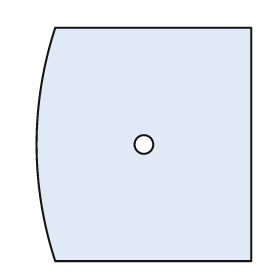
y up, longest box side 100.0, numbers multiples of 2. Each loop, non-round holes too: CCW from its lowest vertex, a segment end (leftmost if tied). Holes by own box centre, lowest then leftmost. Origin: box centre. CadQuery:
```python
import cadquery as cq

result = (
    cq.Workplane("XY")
    .moveTo(-38.0, -50.0)
    .lineTo(46.0, -50.0)
    .lineTo(46.0, 50.0)
    .lineTo(-38.0, 50.0)
    .threePointArc((-46.0, 0.0), (-38.0, -50.0))
    .close()
    .moveTo(0.0, 0.0)
    .circle(4.0)
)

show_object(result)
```